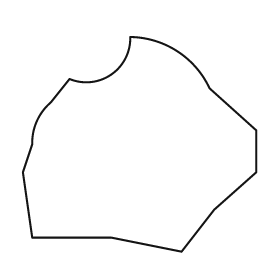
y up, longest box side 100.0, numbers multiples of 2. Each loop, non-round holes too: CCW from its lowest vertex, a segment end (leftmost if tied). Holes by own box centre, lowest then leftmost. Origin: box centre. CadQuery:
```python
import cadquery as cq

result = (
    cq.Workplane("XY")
    .moveTo(18.0, -46.0)
    .lineTo(32.0, -28.0)
    .lineTo(50.0, -12.0)
    .lineTo(50.0, 6.0)
    .lineTo(30.0, 24.0)
    .threePointArc((16.0, 40.0), (-4.0, 46.0))
    .threePointArc((-12.0, 30.0), (-30.0, 28.0))
    .lineTo(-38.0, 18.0)
    .threePointArc((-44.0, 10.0), (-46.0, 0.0))
    .lineTo(-50.0, -12.0)
    .lineTo(-46.0, -40.0)
    .lineTo(-12.0, -40.0)
    .close()
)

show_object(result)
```